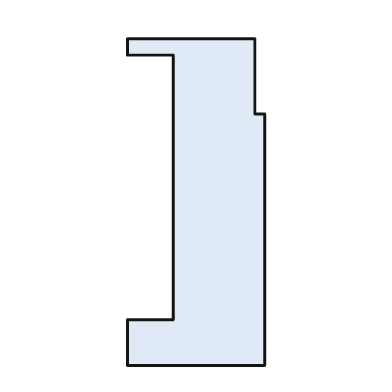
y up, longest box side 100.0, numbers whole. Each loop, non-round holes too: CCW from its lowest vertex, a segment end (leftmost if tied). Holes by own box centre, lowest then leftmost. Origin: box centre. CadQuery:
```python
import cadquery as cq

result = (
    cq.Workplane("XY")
    .moveTo(-21.0, -50.0)
    .lineTo(21.0, -50.0)
    .lineTo(21.0, 27.0)
    .lineTo(18.0, 27.0)
    .lineTo(18.0, 50.0)
    .lineTo(-21.0, 50.0)
    .lineTo(-21.0, 45.0)
    .lineTo(-7.0, 45.0)
    .lineTo(-7.0, -36.0)
    .lineTo(-21.0, -36.0)
    .close()
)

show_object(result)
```